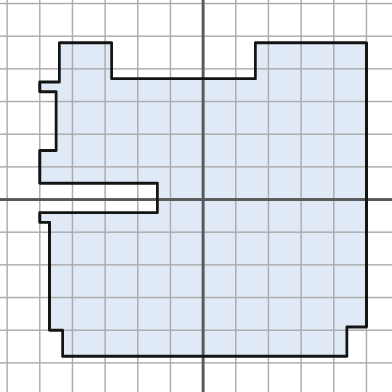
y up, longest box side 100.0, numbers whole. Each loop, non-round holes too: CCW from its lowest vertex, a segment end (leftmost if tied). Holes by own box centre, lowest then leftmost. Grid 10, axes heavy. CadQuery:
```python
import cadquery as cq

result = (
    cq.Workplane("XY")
    .moveTo(-43.0, -48.0)
    .lineTo(44.0, -48.0)
    .lineTo(44.0, -39.0)
    .lineTo(50.0, -39.0)
    .lineTo(50.0, 48.0)
    .lineTo(16.0, 48.0)
    .lineTo(16.0, 37.0)
    .lineTo(-28.0, 37.0)
    .lineTo(-28.0, 48.0)
    .lineTo(-44.0, 48.0)
    .lineTo(-44.0, 36.0)
    .lineTo(-50.0, 36.0)
    .lineTo(-50.0, 33.0)
    .lineTo(-45.0, 33.0)
    .lineTo(-45.0, 15.0)
    .lineTo(-50.0, 15.0)
    .lineTo(-50.0, 5.0)
    .lineTo(-14.0, 5.0)
    .lineTo(-14.0, -4.0)
    .lineTo(-50.0, -4.0)
    .lineTo(-50.0, -7.0)
    .lineTo(-47.0, -7.0)
    .lineTo(-47.0, -40.0)
    .lineTo(-43.0, -40.0)
    .close()
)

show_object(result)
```